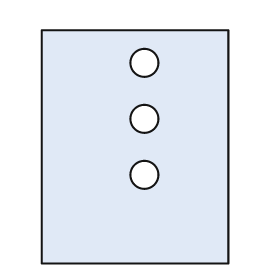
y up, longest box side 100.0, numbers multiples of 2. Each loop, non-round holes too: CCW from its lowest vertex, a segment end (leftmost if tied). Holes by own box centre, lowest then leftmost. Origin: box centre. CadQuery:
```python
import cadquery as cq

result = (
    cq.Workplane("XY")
    .moveTo(-40.0, -50.0)
    .lineTo(40.0, -50.0)
    .lineTo(40.0, 50.0)
    .lineTo(-40.0, 50.0)
    .close()
    .moveTo(4.0, -12.0)
    .circle(6.0)
    .moveTo(4.0, 12.0)
    .circle(6.0)
    .moveTo(4.0, 36.0)
    .circle(6.0)
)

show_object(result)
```